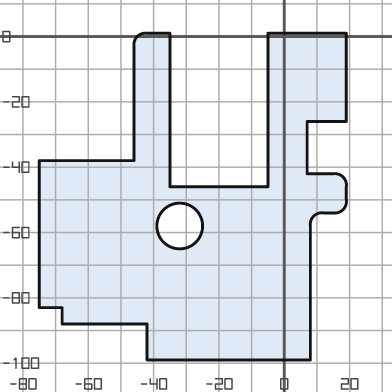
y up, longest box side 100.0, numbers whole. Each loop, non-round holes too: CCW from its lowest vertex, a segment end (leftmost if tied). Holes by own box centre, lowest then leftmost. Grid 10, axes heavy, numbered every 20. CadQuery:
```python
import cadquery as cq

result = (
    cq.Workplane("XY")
    .moveTo(-42.0, -99.0)
    .lineTo(8.0, -99.0)
    .lineTo(8.0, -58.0)
    .threePointArc((9.0, -55.0), (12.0, -54.0))
    .lineTo(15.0, -54.0)
    .threePointArc((18.0, -53.0), (19.0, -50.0))
    .lineTo(19.0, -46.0)
    .threePointArc((18.0, -43.0), (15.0, -42.0))
    .lineTo(7.0, -42.0)
    .lineTo(7.0, -26.0)
    .lineTo(19.0, -26.0)
    .lineTo(19.0, 1.0)
    .lineTo(-5.0, 1.0)
    .lineTo(-5.0, -46.0)
    .lineTo(-35.0, -46.0)
    .lineTo(-35.0, 1.0)
    .lineTo(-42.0, 1.0)
    .threePointArc((-45.0, 0.0), (-46.0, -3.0))
    .lineTo(-46.0, -38.0)
    .lineTo(-75.0, -38.0)
    .lineTo(-75.0, -83.0)
    .lineTo(-68.0, -83.0)
    .lineTo(-68.0, -88.0)
    .lineTo(-42.0, -88.0)
    .close()
    .moveTo(-32.0, -58.0)
    .circle(7.0)
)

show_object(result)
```